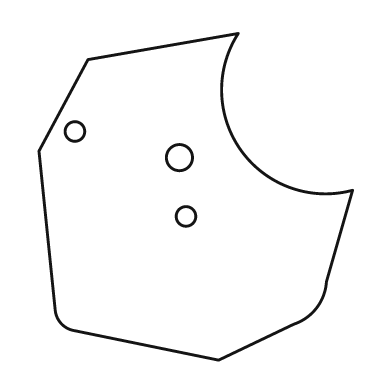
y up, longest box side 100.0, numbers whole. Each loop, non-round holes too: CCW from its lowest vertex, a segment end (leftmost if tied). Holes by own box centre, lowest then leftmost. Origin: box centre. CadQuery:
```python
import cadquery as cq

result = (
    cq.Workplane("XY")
    .moveTo(7.0, -50.0)
    .lineTo(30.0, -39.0)
    .threePointArc((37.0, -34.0), (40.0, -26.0))
    .lineTo(48.0, 2.0)
    .threePointArc((14.0, 14.0), (13.0, 50.0))
    .lineTo(-33.0, 42.0)
    .lineTo(-48.0, 14.0)
    .lineTo(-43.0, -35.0)
    .threePointArc((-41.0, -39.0), (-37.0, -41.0))
    .close()
    .moveTo(-3.0, -6.0)
    .circle(3.0)
    .moveTo(-5.0, 12.0)
    .circle(4.0)
    .moveTo(-37.0, 20.0)
    .circle(3.0)
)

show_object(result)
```